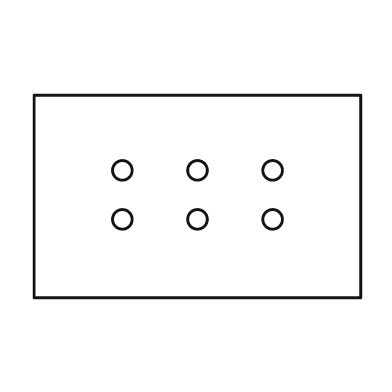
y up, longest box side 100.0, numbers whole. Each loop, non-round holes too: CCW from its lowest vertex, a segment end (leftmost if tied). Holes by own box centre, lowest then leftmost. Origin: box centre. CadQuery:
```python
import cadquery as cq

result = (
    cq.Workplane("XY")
    .moveTo(-50.0, -31.0)
    .lineTo(50.0, -31.0)
    .lineTo(50.0, 31.0)
    .lineTo(-50.0, 31.0)
    .close()
    .moveTo(-23.0, -7.0)
    .circle(3.0)
    .moveTo(0.0, -7.0)
    .circle(3.0)
    .moveTo(23.0, -7.0)
    .circle(3.0)
    .moveTo(-23.0, 8.0)
    .circle(3.0)
    .moveTo(0.0, 8.0)
    .circle(3.0)
    .moveTo(23.0, 8.0)
    .circle(3.0)
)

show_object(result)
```